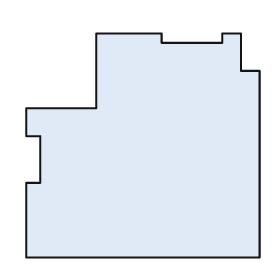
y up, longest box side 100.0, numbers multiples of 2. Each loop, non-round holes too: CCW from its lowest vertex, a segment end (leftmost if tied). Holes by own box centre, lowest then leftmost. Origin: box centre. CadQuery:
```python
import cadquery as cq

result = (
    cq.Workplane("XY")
    .moveTo(-50.0, -48.0)
    .lineTo(50.0, -48.0)
    .lineTo(50.0, 32.0)
    .lineTo(42.0, 32.0)
    .lineTo(42.0, 48.0)
    .lineTo(34.0, 48.0)
    .lineTo(34.0, 44.0)
    .lineTo(8.0, 44.0)
    .lineTo(8.0, 48.0)
    .lineTo(-20.0, 48.0)
    .lineTo(-20.0, 16.0)
    .lineTo(-50.0, 16.0)
    .lineTo(-50.0, 4.0)
    .lineTo(-44.0, 4.0)
    .lineTo(-44.0, -16.0)
    .lineTo(-50.0, -16.0)
    .close()
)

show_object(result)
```